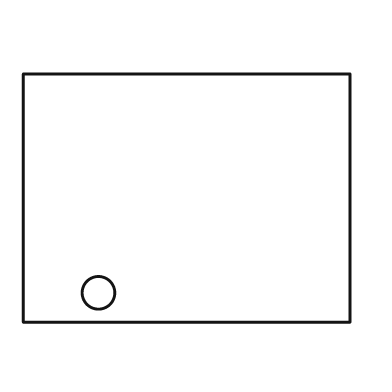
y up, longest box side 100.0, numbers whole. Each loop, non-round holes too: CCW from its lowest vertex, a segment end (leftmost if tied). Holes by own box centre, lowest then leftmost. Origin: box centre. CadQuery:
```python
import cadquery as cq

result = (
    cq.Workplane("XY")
    .moveTo(-50.0, -38.0)
    .lineTo(50.0, -38.0)
    .lineTo(50.0, 38.0)
    .lineTo(-50.0, 38.0)
    .close()
    .moveTo(-27.0, -29.0)
    .circle(5.0)
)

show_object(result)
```